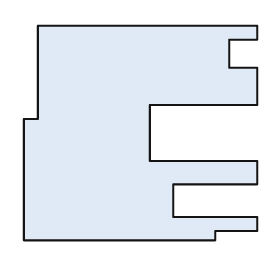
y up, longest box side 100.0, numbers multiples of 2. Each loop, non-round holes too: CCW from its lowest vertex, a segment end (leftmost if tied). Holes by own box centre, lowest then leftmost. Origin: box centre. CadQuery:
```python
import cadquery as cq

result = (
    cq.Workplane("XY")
    .moveTo(-50.0, -46.0)
    .lineTo(32.0, -46.0)
    .lineTo(32.0, -42.0)
    .lineTo(50.0, -42.0)
    .lineTo(50.0, -36.0)
    .lineTo(14.0, -36.0)
    .lineTo(14.0, -22.0)
    .lineTo(50.0, -22.0)
    .lineTo(50.0, -12.0)
    .lineTo(4.0, -12.0)
    .lineTo(4.0, 12.0)
    .lineTo(50.0, 12.0)
    .lineTo(50.0, 28.0)
    .lineTo(38.0, 28.0)
    .lineTo(38.0, 40.0)
    .lineTo(50.0, 40.0)
    .lineTo(50.0, 46.0)
    .lineTo(-44.0, 46.0)
    .lineTo(-44.0, 6.0)
    .lineTo(-50.0, 6.0)
    .close()
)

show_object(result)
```